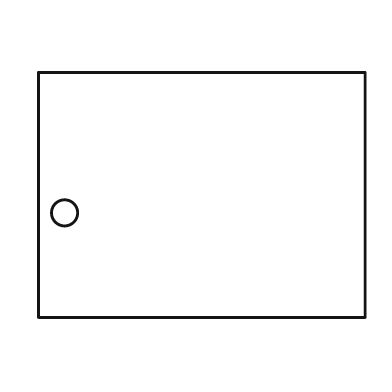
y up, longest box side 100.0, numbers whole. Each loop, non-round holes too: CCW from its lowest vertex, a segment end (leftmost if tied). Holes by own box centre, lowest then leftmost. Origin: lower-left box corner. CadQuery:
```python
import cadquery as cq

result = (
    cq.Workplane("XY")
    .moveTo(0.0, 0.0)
    .lineTo(100.0, 0.0)
    .lineTo(100.0, 75.0)
    .lineTo(0.0, 75.0)
    .close()
    .moveTo(8.0, 32.0)
    .circle(4.0)
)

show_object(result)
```